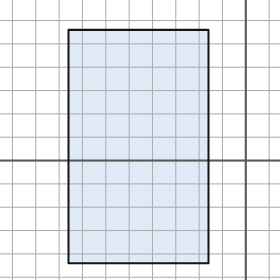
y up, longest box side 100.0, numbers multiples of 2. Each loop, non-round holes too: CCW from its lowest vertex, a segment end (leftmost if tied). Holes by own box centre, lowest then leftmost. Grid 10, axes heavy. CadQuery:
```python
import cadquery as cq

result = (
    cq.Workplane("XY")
    .moveTo(-76.0, -44.0)
    .lineTo(-16.0, -44.0)
    .lineTo(-16.0, 56.0)
    .lineTo(-76.0, 56.0)
    .close()
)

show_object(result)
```